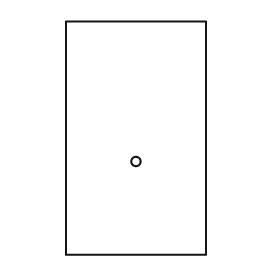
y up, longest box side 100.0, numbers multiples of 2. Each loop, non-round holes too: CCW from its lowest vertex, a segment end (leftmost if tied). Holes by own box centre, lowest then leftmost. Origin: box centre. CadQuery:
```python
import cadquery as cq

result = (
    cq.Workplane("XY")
    .moveTo(-30.0, -50.0)
    .lineTo(30.0, -50.0)
    .lineTo(30.0, 50.0)
    .lineTo(-30.0, 50.0)
    .close()
    .moveTo(0.0, -10.0)
    .circle(2.0)
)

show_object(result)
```